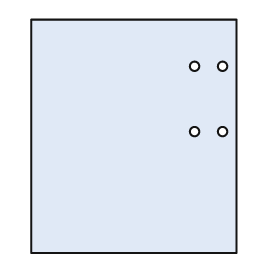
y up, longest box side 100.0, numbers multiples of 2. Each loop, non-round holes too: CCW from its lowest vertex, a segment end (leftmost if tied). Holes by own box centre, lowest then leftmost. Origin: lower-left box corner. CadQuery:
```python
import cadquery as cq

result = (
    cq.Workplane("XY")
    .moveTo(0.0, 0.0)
    .lineTo(88.0, 0.0)
    .lineTo(88.0, 100.0)
    .lineTo(0.0, 100.0)
    .close()
    .moveTo(70.0, 52.0)
    .circle(2.0)
    .moveTo(82.0, 52.0)
    .circle(2.0)
    .moveTo(70.0, 80.0)
    .circle(2.0)
    .moveTo(82.0, 80.0)
    .circle(2.0)
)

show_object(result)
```